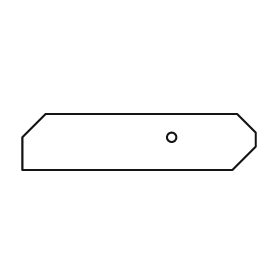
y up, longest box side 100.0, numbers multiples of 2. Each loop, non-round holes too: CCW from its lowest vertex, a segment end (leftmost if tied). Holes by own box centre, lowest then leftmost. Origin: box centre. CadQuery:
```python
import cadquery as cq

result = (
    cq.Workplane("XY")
    .moveTo(-50.0, -12.0)
    .lineTo(40.0, -12.0)
    .lineTo(50.0, -2.0)
    .lineTo(50.0, 4.0)
    .lineTo(42.0, 12.0)
    .lineTo(-40.0, 12.0)
    .lineTo(-50.0, 2.0)
    .close()
    .moveTo(14.0, 2.0)
    .circle(2.0)
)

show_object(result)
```